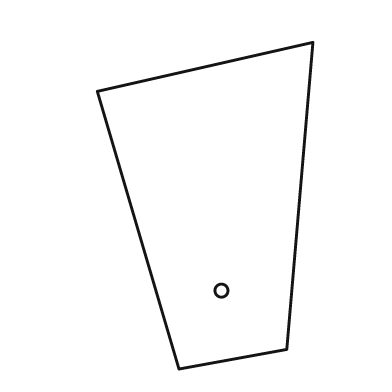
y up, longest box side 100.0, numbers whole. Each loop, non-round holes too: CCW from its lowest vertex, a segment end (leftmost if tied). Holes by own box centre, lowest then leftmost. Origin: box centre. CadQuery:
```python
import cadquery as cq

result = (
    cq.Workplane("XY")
    .moveTo(-8.0, -50.0)
    .lineTo(25.0, -44.0)
    .lineTo(33.0, 50.0)
    .lineTo(-33.0, 35.0)
    .close()
    .moveTo(5.0, -26.0)
    .circle(2.0)
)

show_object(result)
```